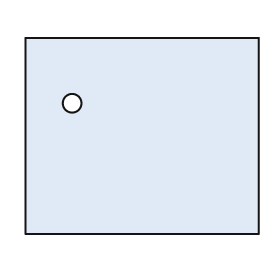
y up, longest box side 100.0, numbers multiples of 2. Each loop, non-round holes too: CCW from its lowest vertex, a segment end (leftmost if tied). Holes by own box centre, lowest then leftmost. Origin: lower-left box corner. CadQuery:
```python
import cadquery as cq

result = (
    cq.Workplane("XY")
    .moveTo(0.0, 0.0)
    .lineTo(100.0, 0.0)
    .lineTo(100.0, 84.0)
    .lineTo(0.0, 84.0)
    .close()
    .moveTo(20.0, 56.0)
    .circle(4.0)
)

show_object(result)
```